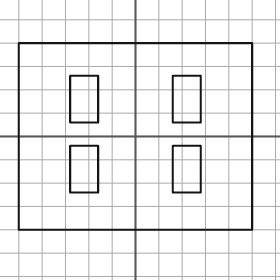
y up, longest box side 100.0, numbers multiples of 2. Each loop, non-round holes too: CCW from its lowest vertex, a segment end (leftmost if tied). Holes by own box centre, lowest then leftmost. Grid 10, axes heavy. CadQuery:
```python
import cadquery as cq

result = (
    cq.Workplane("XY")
    .moveTo(-50.0, -40.0)
    .lineTo(50.0, -40.0)
    .lineTo(50.0, 40.0)
    .lineTo(-50.0, 40.0)
    .close()
    .moveTo(-28.0, -24.0)
    .lineTo(-16.0, -24.0)
    .lineTo(-16.0, -4.0)
    .lineTo(-28.0, -4.0)
    .close()
    .moveTo(16.0, -24.0)
    .lineTo(28.0, -24.0)
    .lineTo(28.0, -4.0)
    .lineTo(16.0, -4.0)
    .close()
    .moveTo(-28.0, 6.0)
    .lineTo(-16.0, 6.0)
    .lineTo(-16.0, 26.0)
    .lineTo(-28.0, 26.0)
    .close()
    .moveTo(16.0, 6.0)
    .lineTo(28.0, 6.0)
    .lineTo(28.0, 26.0)
    .lineTo(16.0, 26.0)
    .close()
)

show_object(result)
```